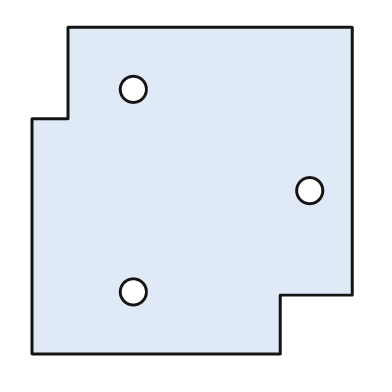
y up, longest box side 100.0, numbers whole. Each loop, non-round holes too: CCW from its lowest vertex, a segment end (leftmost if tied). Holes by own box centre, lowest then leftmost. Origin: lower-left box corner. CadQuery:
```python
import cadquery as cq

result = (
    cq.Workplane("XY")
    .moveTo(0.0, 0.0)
    .lineTo(76.0, 0.0)
    .lineTo(76.0, 18.0)
    .lineTo(98.0, 18.0)
    .lineTo(98.0, 100.0)
    .lineTo(11.0, 100.0)
    .lineTo(11.0, 72.0)
    .lineTo(0.0, 72.0)
    .close()
    .moveTo(31.0, 19.0)
    .circle(4.0)
    .moveTo(85.0, 50.0)
    .circle(4.0)
    .moveTo(31.0, 81.0)
    .circle(4.0)
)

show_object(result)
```